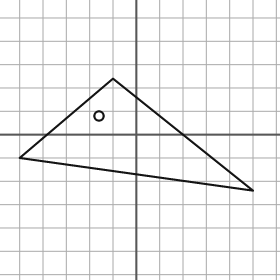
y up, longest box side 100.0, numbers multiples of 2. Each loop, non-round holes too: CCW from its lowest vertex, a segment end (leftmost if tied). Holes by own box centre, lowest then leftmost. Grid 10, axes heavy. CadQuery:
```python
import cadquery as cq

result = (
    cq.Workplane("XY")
    .moveTo(50.0, -24.0)
    .lineTo(-10.0, 24.0)
    .lineTo(-50.0, -10.0)
    .close()
    .moveTo(-16.0, 8.0)
    .circle(2.0)
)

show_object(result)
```